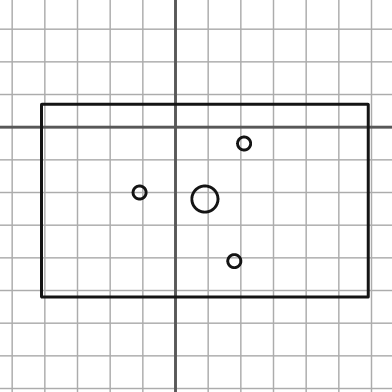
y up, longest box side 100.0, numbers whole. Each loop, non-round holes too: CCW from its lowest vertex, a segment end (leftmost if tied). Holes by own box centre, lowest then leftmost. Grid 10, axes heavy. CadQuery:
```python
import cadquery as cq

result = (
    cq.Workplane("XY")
    .moveTo(-41.0, -52.0)
    .lineTo(59.0, -52.0)
    .lineTo(59.0, 7.0)
    .lineTo(-41.0, 7.0)
    .close()
    .moveTo(18.0, -41.0)
    .circle(2.0)
    .moveTo(9.0, -22.0)
    .circle(4.0)
    .moveTo(-11.0, -20.0)
    .circle(2.0)
    .moveTo(21.0, -5.0)
    .circle(2.0)
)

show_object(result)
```